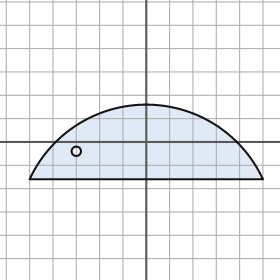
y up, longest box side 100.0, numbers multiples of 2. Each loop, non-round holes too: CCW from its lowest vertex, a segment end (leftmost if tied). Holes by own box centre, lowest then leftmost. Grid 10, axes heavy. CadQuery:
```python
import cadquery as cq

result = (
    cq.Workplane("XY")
    .moveTo(-50.0, -16.0)
    .lineTo(50.0, -16.0)
    .threePointArc((0.0, 16.0), (-50.0, -16.0))
    .close()
    .moveTo(-30.0, -4.0)
    .circle(2.0)
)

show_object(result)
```